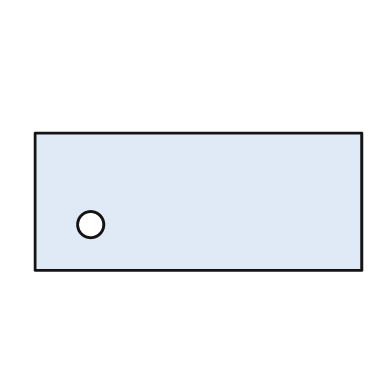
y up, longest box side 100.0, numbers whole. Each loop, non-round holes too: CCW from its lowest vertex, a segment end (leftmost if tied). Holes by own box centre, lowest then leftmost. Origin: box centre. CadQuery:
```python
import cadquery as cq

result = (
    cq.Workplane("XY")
    .moveTo(-50.0, -21.0)
    .lineTo(50.0, -21.0)
    .lineTo(50.0, 21.0)
    .lineTo(-50.0, 21.0)
    .close()
    .moveTo(-33.0, -7.0)
    .circle(4.0)
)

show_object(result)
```